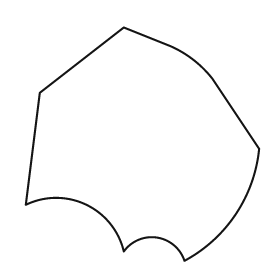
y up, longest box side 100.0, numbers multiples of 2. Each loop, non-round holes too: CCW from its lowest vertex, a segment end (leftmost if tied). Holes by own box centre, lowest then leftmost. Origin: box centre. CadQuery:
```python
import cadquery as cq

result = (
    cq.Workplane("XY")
    .moveTo(18.0, -50.0)
    .threePointArc((40.0, -30.0), (50.0, -2.0))
    .lineTo(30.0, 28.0)
    .threePointArc((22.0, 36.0), (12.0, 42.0))
    .lineTo(-8.0, 50.0)
    .lineTo(-44.0, 22.0)
    .lineTo(-50.0, -26.0)
    .threePointArc((-24.0, -26.0), (-8.0, -46.0))
    .threePointArc((6.0, -40.0), (18.0, -50.0))
    .close()
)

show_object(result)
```